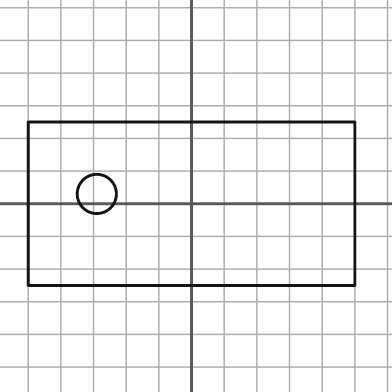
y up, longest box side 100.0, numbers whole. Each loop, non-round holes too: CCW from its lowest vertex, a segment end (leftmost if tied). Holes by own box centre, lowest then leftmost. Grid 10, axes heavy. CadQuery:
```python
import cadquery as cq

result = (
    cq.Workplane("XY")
    .moveTo(-50.0, -25.0)
    .lineTo(50.0, -25.0)
    .lineTo(50.0, 25.0)
    .lineTo(-50.0, 25.0)
    .close()
    .moveTo(-29.0, 3.0)
    .circle(6.0)
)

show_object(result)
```